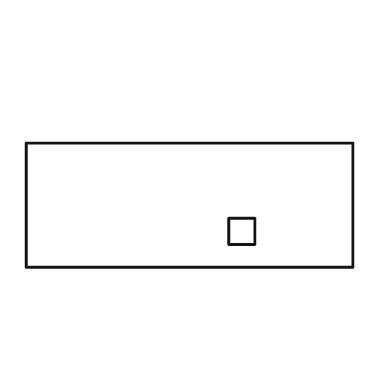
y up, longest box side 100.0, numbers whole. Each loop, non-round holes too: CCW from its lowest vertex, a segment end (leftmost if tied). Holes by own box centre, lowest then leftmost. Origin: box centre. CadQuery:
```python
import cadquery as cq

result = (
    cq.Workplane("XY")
    .moveTo(-50.0, -19.0)
    .lineTo(50.0, -19.0)
    .lineTo(50.0, 19.0)
    .lineTo(-50.0, 19.0)
    .close()
    .moveTo(12.0, -12.0)
    .lineTo(20.0, -12.0)
    .lineTo(20.0, -4.0)
    .lineTo(12.0, -4.0)
    .close()
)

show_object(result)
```